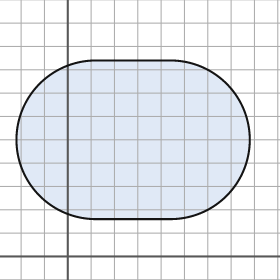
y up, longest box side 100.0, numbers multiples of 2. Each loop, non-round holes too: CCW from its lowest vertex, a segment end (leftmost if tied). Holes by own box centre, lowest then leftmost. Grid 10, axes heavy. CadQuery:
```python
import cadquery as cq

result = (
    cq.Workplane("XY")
    .moveTo(12.0, 16.0)
    .lineTo(44.0, 16.0)
    .threePointArc((78.0, 50.0), (44.0, 84.0))
    .lineTo(12.0, 84.0)
    .threePointArc((-22.0, 50.0), (12.0, 16.0))
    .close()
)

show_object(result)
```